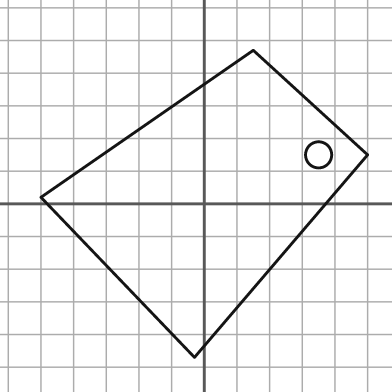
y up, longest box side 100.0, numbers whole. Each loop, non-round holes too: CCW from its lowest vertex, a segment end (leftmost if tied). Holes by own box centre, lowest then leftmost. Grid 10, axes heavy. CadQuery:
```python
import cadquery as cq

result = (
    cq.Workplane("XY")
    .moveTo(-3.0, -47.0)
    .lineTo(50.0, 15.0)
    .lineTo(15.0, 47.0)
    .lineTo(-50.0, 2.0)
    .close()
    .moveTo(35.0, 15.0)
    .circle(4.0)
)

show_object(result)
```